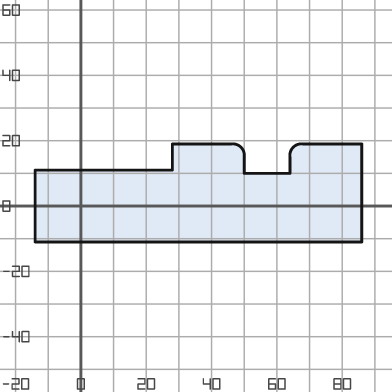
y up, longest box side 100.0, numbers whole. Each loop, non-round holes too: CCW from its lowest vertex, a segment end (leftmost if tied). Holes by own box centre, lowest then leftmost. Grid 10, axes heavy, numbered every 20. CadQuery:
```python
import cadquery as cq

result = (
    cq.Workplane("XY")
    .moveTo(-14.0, -11.0)
    .lineTo(86.0, -11.0)
    .lineTo(86.0, 19.0)
    .lineTo(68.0, 19.0)
    .threePointArc((65.0, 18.0), (64.0, 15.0))
    .lineTo(64.0, 10.0)
    .lineTo(50.0, 10.0)
    .lineTo(50.0, 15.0)
    .threePointArc((49.0, 18.0), (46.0, 19.0))
    .lineTo(28.0, 19.0)
    .lineTo(28.0, 11.0)
    .lineTo(-14.0, 11.0)
    .close()
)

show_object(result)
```